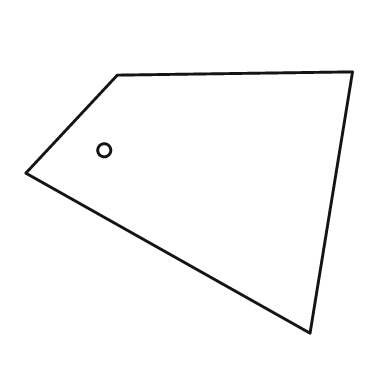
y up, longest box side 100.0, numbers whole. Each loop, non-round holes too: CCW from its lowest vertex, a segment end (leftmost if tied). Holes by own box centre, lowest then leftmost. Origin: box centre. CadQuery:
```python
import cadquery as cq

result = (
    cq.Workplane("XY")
    .moveTo(37.0, -40.0)
    .lineTo(50.0, 40.0)
    .lineTo(-22.0, 39.0)
    .lineTo(-50.0, 9.0)
    .close()
    .moveTo(-26.0, 16.0)
    .circle(2.0)
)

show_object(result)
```